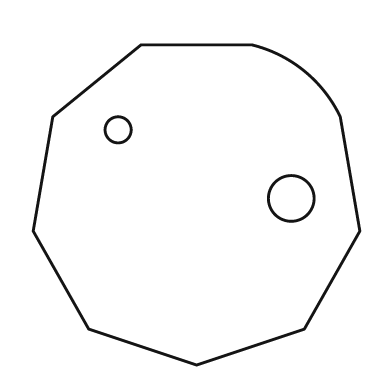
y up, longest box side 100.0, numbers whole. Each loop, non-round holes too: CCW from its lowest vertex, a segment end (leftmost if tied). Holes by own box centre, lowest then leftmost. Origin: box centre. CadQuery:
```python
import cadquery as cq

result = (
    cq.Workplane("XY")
    .moveTo(0.0, -49.0)
    .lineTo(33.0, -38.0)
    .lineTo(50.0, -8.0)
    .lineTo(44.0, 27.0)
    .threePointArc((33.0, 41.0), (17.0, 49.0))
    .lineTo(-17.0, 49.0)
    .lineTo(-44.0, 27.0)
    .lineTo(-50.0, -8.0)
    .lineTo(-33.0, -38.0)
    .close()
    .moveTo(29.0, 2.0)
    .circle(7.0)
    .moveTo(-24.0, 23.0)
    .circle(4.0)
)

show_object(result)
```